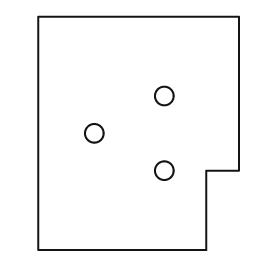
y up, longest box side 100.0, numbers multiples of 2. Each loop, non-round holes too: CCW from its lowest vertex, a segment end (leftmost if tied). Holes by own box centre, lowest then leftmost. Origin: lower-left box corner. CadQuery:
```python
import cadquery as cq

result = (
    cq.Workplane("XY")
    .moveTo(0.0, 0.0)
    .lineTo(72.0, 0.0)
    .lineTo(72.0, 34.0)
    .lineTo(86.0, 34.0)
    .lineTo(86.0, 100.0)
    .lineTo(0.0, 100.0)
    .close()
    .moveTo(54.0, 34.0)
    .circle(4.0)
    .moveTo(24.0, 50.0)
    .circle(4.0)
    .moveTo(54.0, 66.0)
    .circle(4.0)
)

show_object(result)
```